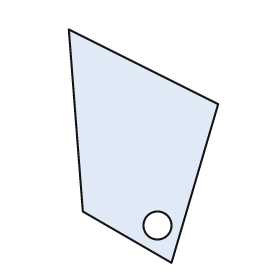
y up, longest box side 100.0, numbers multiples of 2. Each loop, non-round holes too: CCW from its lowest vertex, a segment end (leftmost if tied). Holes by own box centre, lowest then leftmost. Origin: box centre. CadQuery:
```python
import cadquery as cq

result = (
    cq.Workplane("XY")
    .moveTo(12.0, -50.0)
    .lineTo(32.0, 18.0)
    .lineTo(-32.0, 50.0)
    .lineTo(-26.0, -28.0)
    .close()
    .moveTo(6.0, -34.0)
    .circle(6.0)
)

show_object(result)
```